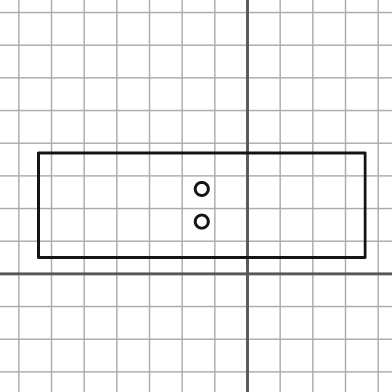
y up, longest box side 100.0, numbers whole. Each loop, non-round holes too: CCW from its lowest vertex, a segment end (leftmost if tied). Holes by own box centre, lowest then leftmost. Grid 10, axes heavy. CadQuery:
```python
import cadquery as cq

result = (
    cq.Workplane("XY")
    .moveTo(-64.0, 5.0)
    .lineTo(36.0, 5.0)
    .lineTo(36.0, 37.0)
    .lineTo(-64.0, 37.0)
    .close()
    .moveTo(-14.0, 16.0)
    .circle(2.0)
    .moveTo(-14.0, 26.0)
    .circle(2.0)
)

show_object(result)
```